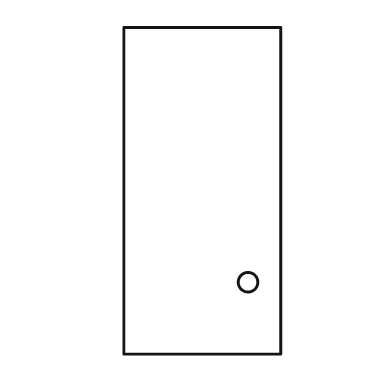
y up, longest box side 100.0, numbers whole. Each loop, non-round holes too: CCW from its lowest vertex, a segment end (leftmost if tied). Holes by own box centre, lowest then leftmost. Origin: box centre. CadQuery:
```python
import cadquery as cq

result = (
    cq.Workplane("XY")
    .moveTo(-24.0, -50.0)
    .lineTo(24.0, -50.0)
    .lineTo(24.0, 50.0)
    .lineTo(-24.0, 50.0)
    .close()
    .moveTo(14.0, -28.0)
    .circle(3.0)
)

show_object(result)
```